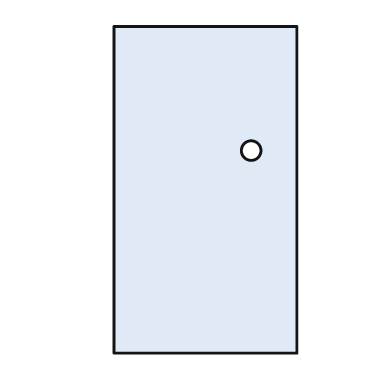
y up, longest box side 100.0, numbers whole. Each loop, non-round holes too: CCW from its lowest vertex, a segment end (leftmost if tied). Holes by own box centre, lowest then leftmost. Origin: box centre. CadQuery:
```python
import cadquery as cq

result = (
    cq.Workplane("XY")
    .moveTo(-28.0, -50.0)
    .lineTo(28.0, -50.0)
    .lineTo(28.0, 50.0)
    .lineTo(-28.0, 50.0)
    .close()
    .moveTo(14.0, 12.0)
    .circle(3.0)
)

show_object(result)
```